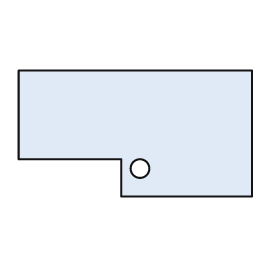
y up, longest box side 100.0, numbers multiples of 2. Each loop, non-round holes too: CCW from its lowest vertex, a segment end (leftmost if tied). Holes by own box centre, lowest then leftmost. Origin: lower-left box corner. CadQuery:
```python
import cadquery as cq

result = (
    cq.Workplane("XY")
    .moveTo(44.0, 0.0)
    .lineTo(100.0, 0.0)
    .lineTo(100.0, 54.0)
    .lineTo(0.0, 54.0)
    .lineTo(0.0, 16.0)
    .lineTo(44.0, 16.0)
    .close()
    .moveTo(52.0, 12.0)
    .circle(4.0)
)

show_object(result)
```